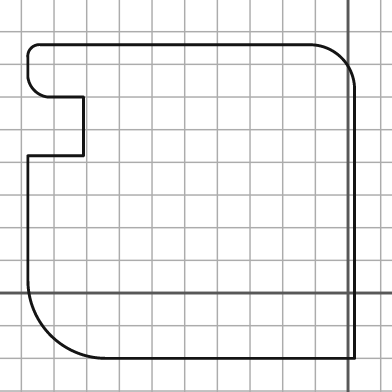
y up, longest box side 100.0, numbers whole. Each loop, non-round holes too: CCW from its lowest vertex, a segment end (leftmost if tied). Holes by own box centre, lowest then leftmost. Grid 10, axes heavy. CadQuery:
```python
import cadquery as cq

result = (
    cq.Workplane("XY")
    .moveTo(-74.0, -20.0)
    .lineTo(2.0, -20.0)
    .lineTo(2.0, 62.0)
    .threePointArc((-2.0, 72.0), (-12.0, 76.0))
    .lineTo(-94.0, 76.0)
    .threePointArc((-97.0, 75.0), (-98.0, 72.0))
    .lineTo(-98.0, 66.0)
    .threePointArc((-96.0, 62.0), (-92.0, 60.0))
    .lineTo(-81.0, 60.0)
    .lineTo(-81.0, 42.0)
    .lineTo(-98.0, 42.0)
    .lineTo(-98.0, 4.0)
    .threePointArc((-91.0, -13.0), (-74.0, -20.0))
    .close()
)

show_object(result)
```